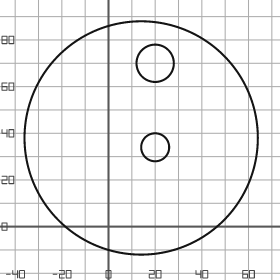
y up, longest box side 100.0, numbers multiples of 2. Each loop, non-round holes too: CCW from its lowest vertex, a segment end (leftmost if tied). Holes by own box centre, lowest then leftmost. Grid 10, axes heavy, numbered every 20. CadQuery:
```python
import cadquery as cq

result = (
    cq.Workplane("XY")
    .moveTo(14.0, 38.0)
    .circle(50.0)
    .moveTo(20.0, 34.0)
    .circle(6.0)
    .moveTo(20.0, 70.0)
    .circle(8.0)
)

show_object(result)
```